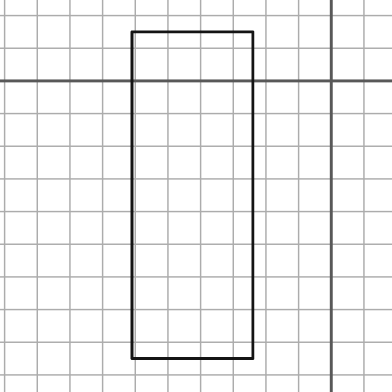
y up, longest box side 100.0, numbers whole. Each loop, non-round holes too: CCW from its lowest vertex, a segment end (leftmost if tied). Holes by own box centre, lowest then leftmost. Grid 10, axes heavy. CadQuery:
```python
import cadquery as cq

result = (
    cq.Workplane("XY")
    .moveTo(-61.0, -85.0)
    .lineTo(-24.0, -85.0)
    .lineTo(-24.0, 15.0)
    .lineTo(-61.0, 15.0)
    .close()
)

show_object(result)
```